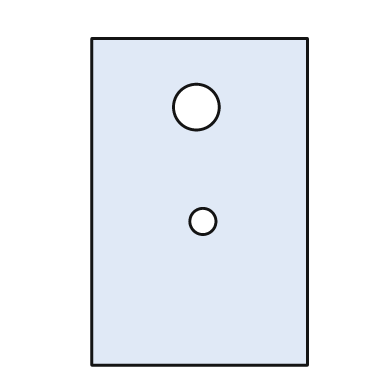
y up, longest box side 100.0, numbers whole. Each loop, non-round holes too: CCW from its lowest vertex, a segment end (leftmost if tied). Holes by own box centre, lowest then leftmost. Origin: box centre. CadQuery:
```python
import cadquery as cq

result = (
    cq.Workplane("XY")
    .moveTo(-33.0, -50.0)
    .lineTo(33.0, -50.0)
    .lineTo(33.0, 50.0)
    .lineTo(-33.0, 50.0)
    .close()
    .moveTo(1.0, -6.0)
    .circle(4.0)
    .moveTo(-1.0, 29.0)
    .circle(7.0)
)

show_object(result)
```